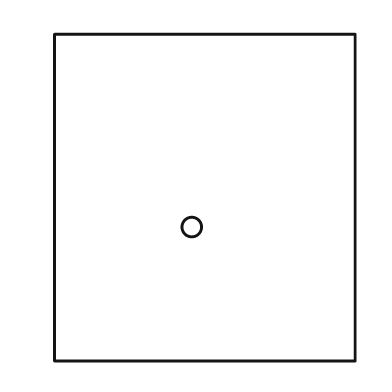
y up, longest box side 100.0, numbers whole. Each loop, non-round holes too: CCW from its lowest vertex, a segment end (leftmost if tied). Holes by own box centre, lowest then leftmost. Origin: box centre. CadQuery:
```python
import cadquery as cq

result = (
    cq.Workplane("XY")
    .moveTo(-46.0, -50.0)
    .lineTo(46.0, -50.0)
    .lineTo(46.0, 50.0)
    .lineTo(-46.0, 50.0)
    .close()
    .moveTo(-4.0, -9.0)
    .circle(3.0)
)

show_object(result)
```